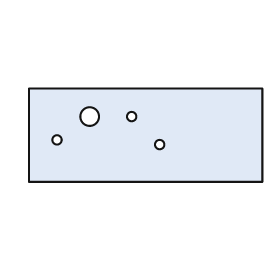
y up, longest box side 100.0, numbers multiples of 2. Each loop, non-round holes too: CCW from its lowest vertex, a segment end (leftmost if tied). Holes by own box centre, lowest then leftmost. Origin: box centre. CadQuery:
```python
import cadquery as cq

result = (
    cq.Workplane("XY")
    .moveTo(-50.0, -20.0)
    .lineTo(50.0, -20.0)
    .lineTo(50.0, 20.0)
    .lineTo(-50.0, 20.0)
    .close()
    .moveTo(6.0, -4.0)
    .circle(2.0)
    .moveTo(-38.0, -2.0)
    .circle(2.0)
    .moveTo(-24.0, 8.0)
    .circle(4.0)
    .moveTo(-6.0, 8.0)
    .circle(2.0)
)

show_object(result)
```